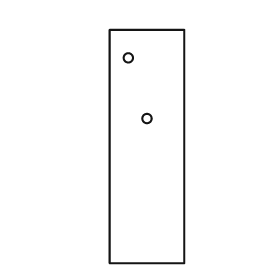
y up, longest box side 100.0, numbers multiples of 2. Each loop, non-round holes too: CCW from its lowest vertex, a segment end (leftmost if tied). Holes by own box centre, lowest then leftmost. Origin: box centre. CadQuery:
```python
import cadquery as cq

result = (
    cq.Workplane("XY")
    .moveTo(-16.0, -50.0)
    .lineTo(16.0, -50.0)
    .lineTo(16.0, 50.0)
    .lineTo(-16.0, 50.0)
    .close()
    .moveTo(0.0, 12.0)
    .circle(2.0)
    .moveTo(-8.0, 38.0)
    .circle(2.0)
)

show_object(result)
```